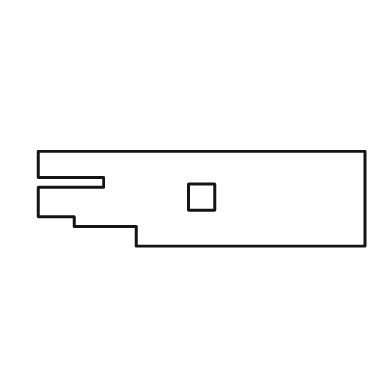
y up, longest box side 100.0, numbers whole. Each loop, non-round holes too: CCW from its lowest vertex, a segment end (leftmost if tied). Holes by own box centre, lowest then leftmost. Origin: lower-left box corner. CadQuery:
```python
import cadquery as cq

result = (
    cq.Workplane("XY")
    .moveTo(30.0, 0.0)
    .lineTo(100.0, 0.0)
    .lineTo(100.0, 29.0)
    .lineTo(0.0, 29.0)
    .lineTo(0.0, 21.0)
    .lineTo(20.0, 21.0)
    .lineTo(20.0, 18.0)
    .lineTo(0.0, 18.0)
    .lineTo(0.0, 9.0)
    .lineTo(11.0, 9.0)
    .lineTo(11.0, 6.0)
    .lineTo(30.0, 6.0)
    .close()
    .moveTo(46.0, 11.0)
    .lineTo(54.0, 11.0)
    .lineTo(54.0, 19.0)
    .lineTo(46.0, 19.0)
    .close()
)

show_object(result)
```